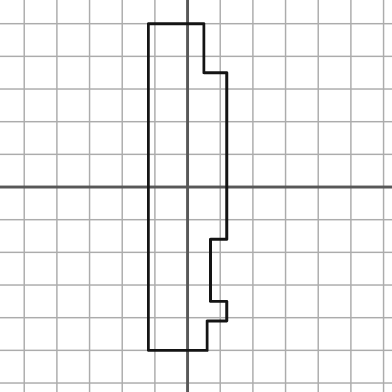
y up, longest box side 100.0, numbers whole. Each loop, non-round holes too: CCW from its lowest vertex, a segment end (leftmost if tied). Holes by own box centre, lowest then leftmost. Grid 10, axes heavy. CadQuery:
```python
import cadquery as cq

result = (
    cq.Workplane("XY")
    .moveTo(-12.0, -50.0)
    .lineTo(6.0, -50.0)
    .lineTo(6.0, -41.0)
    .lineTo(12.0, -41.0)
    .lineTo(12.0, -35.0)
    .lineTo(7.0, -35.0)
    .lineTo(7.0, -16.0)
    .lineTo(12.0, -16.0)
    .lineTo(12.0, 35.0)
    .lineTo(5.0, 35.0)
    .lineTo(5.0, 50.0)
    .lineTo(-12.0, 50.0)
    .close()
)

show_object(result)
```